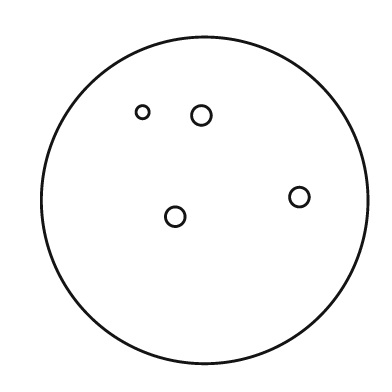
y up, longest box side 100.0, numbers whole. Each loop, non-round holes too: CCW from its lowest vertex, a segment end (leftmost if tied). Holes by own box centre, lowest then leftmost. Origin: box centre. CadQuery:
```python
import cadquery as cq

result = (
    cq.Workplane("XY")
    .moveTo(0.0, 0.0)
    .circle(50.0)
    .moveTo(-9.0, -5.0)
    .circle(3.0)
    .moveTo(29.0, 1.0)
    .circle(3.0)
    .moveTo(-1.0, 26.0)
    .circle(3.0)
    .moveTo(-19.0, 27.0)
    .circle(2.0)
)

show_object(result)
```